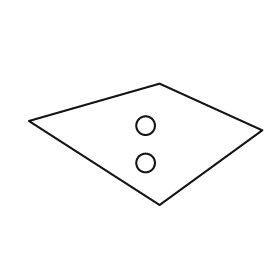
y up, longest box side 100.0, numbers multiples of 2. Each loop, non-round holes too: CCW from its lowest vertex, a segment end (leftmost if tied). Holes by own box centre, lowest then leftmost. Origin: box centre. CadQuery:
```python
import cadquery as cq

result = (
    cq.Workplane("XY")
    .moveTo(6.0, -26.0)
    .lineTo(50.0, 6.0)
    .lineTo(6.0, 26.0)
    .lineTo(-50.0, 10.0)
    .close()
    .moveTo(0.0, -8.0)
    .circle(4.0)
    .moveTo(0.0, 8.0)
    .circle(4.0)
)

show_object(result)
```